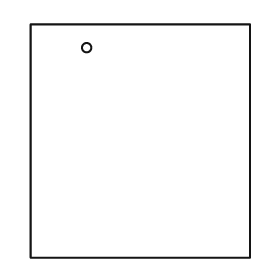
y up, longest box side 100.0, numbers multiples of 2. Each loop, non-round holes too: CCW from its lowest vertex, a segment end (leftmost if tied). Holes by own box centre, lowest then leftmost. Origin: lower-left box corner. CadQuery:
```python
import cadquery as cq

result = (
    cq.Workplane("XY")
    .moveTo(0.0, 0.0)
    .lineTo(94.0, 0.0)
    .lineTo(94.0, 100.0)
    .lineTo(0.0, 100.0)
    .close()
    .moveTo(24.0, 90.0)
    .circle(2.0)
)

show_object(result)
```